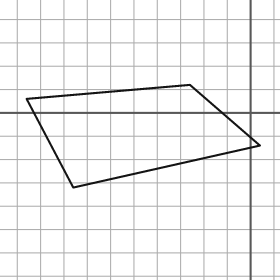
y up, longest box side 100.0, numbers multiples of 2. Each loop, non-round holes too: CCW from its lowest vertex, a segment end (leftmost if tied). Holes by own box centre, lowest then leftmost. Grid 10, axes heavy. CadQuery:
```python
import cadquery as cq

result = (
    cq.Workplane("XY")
    .moveTo(-76.0, -32.0)
    .lineTo(4.0, -14.0)
    .lineTo(-26.0, 12.0)
    .lineTo(-96.0, 6.0)
    .close()
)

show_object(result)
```